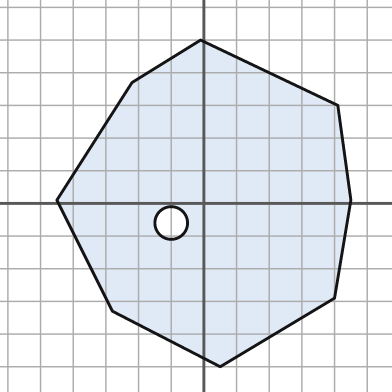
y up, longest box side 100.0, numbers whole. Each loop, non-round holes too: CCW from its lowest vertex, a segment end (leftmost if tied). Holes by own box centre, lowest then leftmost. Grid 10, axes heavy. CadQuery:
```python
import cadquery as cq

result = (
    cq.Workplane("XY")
    .moveTo(5.0, -50.0)
    .lineTo(40.0, -29.0)
    .lineTo(45.0, 1.0)
    .lineTo(41.0, 30.0)
    .lineTo(-1.0, 50.0)
    .lineTo(-22.0, 37.0)
    .lineTo(-45.0, 1.0)
    .lineTo(-28.0, -33.0)
    .close()
    .moveTo(-10.0, -6.0)
    .circle(5.0)
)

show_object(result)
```